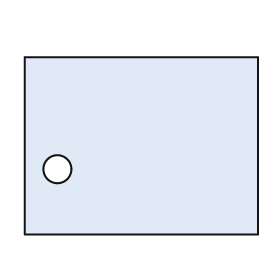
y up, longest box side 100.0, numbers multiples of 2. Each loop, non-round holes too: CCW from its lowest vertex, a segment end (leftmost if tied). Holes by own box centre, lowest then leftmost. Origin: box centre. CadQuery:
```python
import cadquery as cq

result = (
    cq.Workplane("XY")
    .moveTo(-50.0, -38.0)
    .lineTo(50.0, -38.0)
    .lineTo(50.0, 38.0)
    .lineTo(-50.0, 38.0)
    .close()
    .moveTo(-36.0, -10.0)
    .circle(6.0)
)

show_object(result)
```